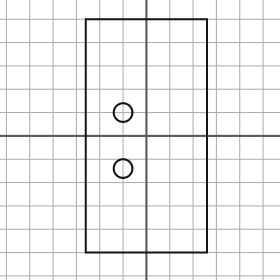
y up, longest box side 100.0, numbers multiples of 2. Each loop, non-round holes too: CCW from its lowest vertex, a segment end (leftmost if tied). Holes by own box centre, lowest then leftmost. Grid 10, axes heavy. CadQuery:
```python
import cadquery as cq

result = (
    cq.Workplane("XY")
    .moveTo(-26.0, -50.0)
    .lineTo(26.0, -50.0)
    .lineTo(26.0, 50.0)
    .lineTo(-26.0, 50.0)
    .close()
    .moveTo(-10.0, -14.0)
    .circle(4.0)
    .moveTo(-10.0, 10.0)
    .circle(4.0)
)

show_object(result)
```